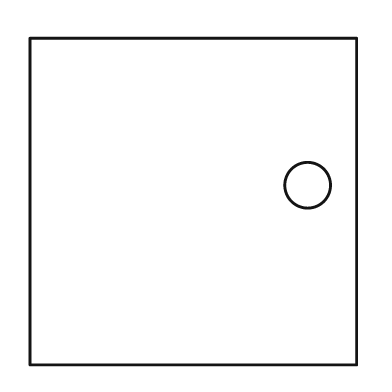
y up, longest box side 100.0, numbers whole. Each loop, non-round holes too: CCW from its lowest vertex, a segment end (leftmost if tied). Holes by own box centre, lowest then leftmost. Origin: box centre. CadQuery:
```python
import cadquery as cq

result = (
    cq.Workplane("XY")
    .moveTo(-50.0, -50.0)
    .lineTo(50.0, -50.0)
    .lineTo(50.0, 50.0)
    .lineTo(-50.0, 50.0)
    .close()
    .moveTo(35.0, 5.0)
    .circle(7.0)
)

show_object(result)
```